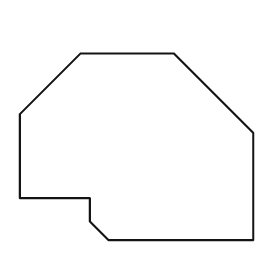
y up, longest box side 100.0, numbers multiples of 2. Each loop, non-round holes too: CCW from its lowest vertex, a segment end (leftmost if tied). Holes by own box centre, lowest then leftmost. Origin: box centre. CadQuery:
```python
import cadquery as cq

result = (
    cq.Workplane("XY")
    .moveTo(-12.0, -40.0)
    .lineTo(50.0, -40.0)
    .lineTo(50.0, 6.0)
    .lineTo(16.0, 40.0)
    .lineTo(-24.0, 40.0)
    .lineTo(-50.0, 14.0)
    .lineTo(-50.0, -22.0)
    .lineTo(-20.0, -22.0)
    .lineTo(-20.0, -32.0)
    .close()
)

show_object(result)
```